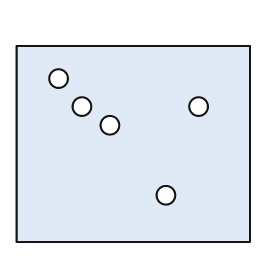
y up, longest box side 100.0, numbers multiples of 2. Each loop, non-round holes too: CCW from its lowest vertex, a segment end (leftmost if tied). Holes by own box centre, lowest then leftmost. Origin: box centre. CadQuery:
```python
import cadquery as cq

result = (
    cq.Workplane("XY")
    .moveTo(-50.0, -42.0)
    .lineTo(50.0, -42.0)
    .lineTo(50.0, 42.0)
    .lineTo(-50.0, 42.0)
    .close()
    .moveTo(14.0, -22.0)
    .circle(4.0)
    .moveTo(-10.0, 8.0)
    .circle(4.0)
    .moveTo(-22.0, 16.0)
    .circle(4.0)
    .moveTo(28.0, 16.0)
    .circle(4.0)
    .moveTo(-32.0, 28.0)
    .circle(4.0)
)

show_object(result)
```